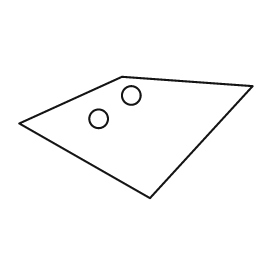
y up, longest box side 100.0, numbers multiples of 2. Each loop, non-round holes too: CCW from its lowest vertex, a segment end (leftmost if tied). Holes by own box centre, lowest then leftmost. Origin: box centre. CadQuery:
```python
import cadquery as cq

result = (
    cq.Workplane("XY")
    .moveTo(6.0, -26.0)
    .lineTo(50.0, 22.0)
    .lineTo(-6.0, 26.0)
    .lineTo(-50.0, 6.0)
    .close()
    .moveTo(-16.0, 8.0)
    .circle(4.0)
    .moveTo(-2.0, 18.0)
    .circle(4.0)
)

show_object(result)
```